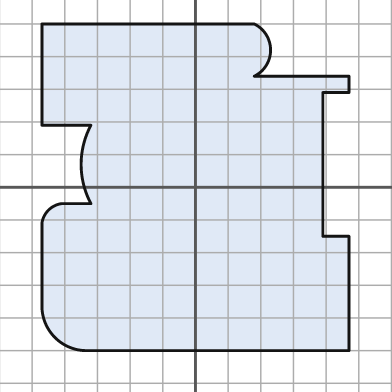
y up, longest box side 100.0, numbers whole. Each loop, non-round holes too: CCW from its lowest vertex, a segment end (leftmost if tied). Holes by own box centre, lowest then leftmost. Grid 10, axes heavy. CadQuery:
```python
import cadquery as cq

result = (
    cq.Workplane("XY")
    .moveTo(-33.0, -50.0)
    .lineTo(47.0, -50.0)
    .lineTo(47.0, -15.0)
    .lineTo(39.0, -15.0)
    .lineTo(39.0, 29.0)
    .lineTo(47.0, 29.0)
    .lineTo(47.0, 34.0)
    .lineTo(18.0, 34.0)
    .threePointArc((23.0, 42.0), (18.0, 50.0))
    .lineTo(-47.0, 50.0)
    .lineTo(-47.0, 19.0)
    .lineTo(-32.0, 19.0)
    .threePointArc((-35.0, 7.0), (-32.0, -5.0))
    .lineTo(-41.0, -5.0)
    .threePointArc((-45.0, -7.0), (-47.0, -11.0))
    .lineTo(-47.0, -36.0)
    .threePointArc((-43.0, -46.0), (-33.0, -50.0))
    .close()
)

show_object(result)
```